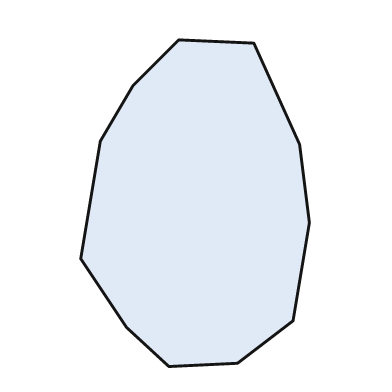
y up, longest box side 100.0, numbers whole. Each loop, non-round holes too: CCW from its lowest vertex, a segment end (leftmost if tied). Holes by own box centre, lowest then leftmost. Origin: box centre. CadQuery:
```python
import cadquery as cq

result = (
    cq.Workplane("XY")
    .moveTo(-8.0, -50.0)
    .lineTo(13.0, -49.0)
    .lineTo(30.0, -36.0)
    .lineTo(35.0, -6.0)
    .lineTo(32.0, 18.0)
    .lineTo(18.0, 49.0)
    .lineTo(-5.0, 50.0)
    .lineTo(-19.0, 36.0)
    .lineTo(-29.0, 19.0)
    .lineTo(-35.0, -17.0)
    .lineTo(-21.0, -38.0)
    .close()
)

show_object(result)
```